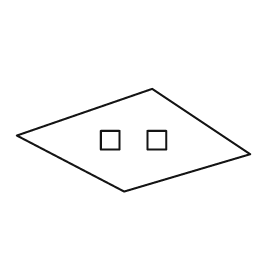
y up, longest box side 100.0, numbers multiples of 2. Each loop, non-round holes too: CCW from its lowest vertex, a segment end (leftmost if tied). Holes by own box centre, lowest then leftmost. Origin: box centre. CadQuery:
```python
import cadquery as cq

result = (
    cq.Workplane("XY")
    .moveTo(-4.0, -22.0)
    .lineTo(50.0, -6.0)
    .lineTo(8.0, 22.0)
    .lineTo(-50.0, 2.0)
    .close()
    .moveTo(-14.0, -4.0)
    .lineTo(-6.0, -4.0)
    .lineTo(-6.0, 4.0)
    .lineTo(-14.0, 4.0)
    .close()
    .moveTo(6.0, -4.0)
    .lineTo(14.0, -4.0)
    .lineTo(14.0, 4.0)
    .lineTo(6.0, 4.0)
    .close()
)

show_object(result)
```